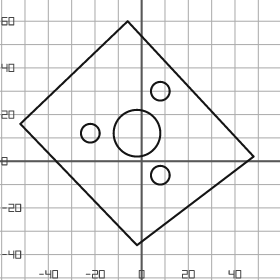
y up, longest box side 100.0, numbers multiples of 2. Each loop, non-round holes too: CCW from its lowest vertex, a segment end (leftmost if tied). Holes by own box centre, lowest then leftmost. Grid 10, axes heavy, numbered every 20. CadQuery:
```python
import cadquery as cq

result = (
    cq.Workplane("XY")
    .moveTo(-2.0, -36.0)
    .lineTo(48.0, 2.0)
    .lineTo(-6.0, 60.0)
    .lineTo(-52.0, 16.0)
    .close()
    .moveTo(8.0, -6.0)
    .circle(4.0)
    .moveTo(-22.0, 12.0)
    .circle(4.0)
    .moveTo(-2.0, 12.0)
    .circle(10.0)
    .moveTo(8.0, 30.0)
    .circle(4.0)
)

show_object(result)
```